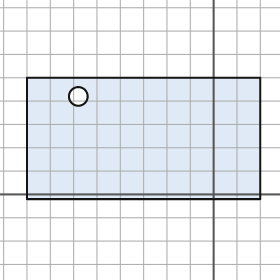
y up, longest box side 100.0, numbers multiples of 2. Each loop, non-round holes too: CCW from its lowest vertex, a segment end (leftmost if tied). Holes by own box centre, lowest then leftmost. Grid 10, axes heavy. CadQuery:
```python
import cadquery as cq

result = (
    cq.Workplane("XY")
    .moveTo(-80.0, -2.0)
    .lineTo(20.0, -2.0)
    .lineTo(20.0, 50.0)
    .lineTo(-80.0, 50.0)
    .close()
    .moveTo(-58.0, 42.0)
    .circle(4.0)
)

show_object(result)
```